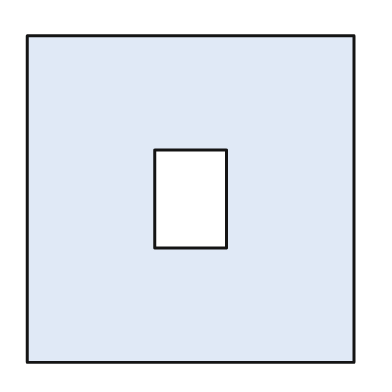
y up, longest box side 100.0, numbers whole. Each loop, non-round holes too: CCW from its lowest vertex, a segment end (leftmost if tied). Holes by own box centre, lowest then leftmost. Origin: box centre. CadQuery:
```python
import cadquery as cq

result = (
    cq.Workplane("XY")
    .moveTo(-50.0, -50.0)
    .lineTo(50.0, -50.0)
    .lineTo(50.0, 50.0)
    .lineTo(-50.0, 50.0)
    .close()
    .moveTo(-11.0, -15.0)
    .lineTo(11.0, -15.0)
    .lineTo(11.0, 15.0)
    .lineTo(-11.0, 15.0)
    .close()
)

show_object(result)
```